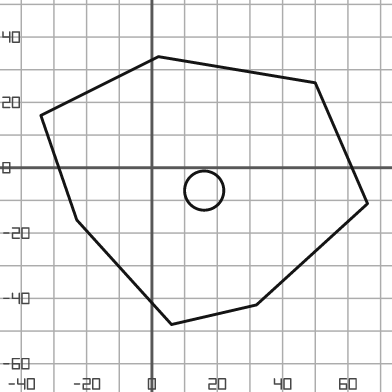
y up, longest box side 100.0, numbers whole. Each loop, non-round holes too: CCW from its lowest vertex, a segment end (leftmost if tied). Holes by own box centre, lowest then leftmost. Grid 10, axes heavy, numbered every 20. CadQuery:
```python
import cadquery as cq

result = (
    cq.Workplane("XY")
    .moveTo(6.0, -48.0)
    .lineTo(32.0, -42.0)
    .lineTo(66.0, -11.0)
    .lineTo(50.0, 26.0)
    .lineTo(2.0, 34.0)
    .lineTo(-34.0, 16.0)
    .lineTo(-23.0, -16.0)
    .close()
    .moveTo(16.0, -7.0)
    .circle(6.0)
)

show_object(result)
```